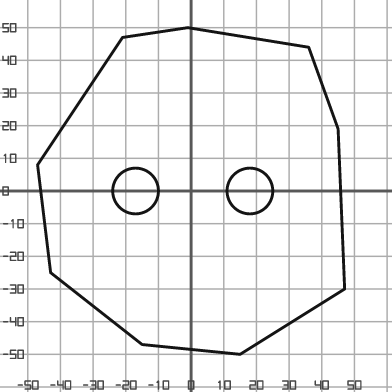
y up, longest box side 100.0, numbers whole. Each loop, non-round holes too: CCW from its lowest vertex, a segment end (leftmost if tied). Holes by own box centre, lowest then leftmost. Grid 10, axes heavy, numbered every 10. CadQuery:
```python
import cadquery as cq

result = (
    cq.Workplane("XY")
    .moveTo(15.0, -50.0)
    .lineTo(47.0, -30.0)
    .lineTo(45.0, 19.0)
    .lineTo(36.0, 44.0)
    .lineTo(-1.0, 50.0)
    .lineTo(-21.0, 47.0)
    .lineTo(-47.0, 8.0)
    .lineTo(-43.0, -25.0)
    .lineTo(-15.0, -47.0)
    .close()
    .moveTo(-17.0, 0.0)
    .circle(7.0)
    .moveTo(18.0, 0.0)
    .circle(7.0)
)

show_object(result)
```